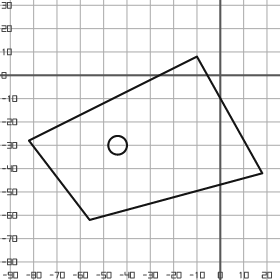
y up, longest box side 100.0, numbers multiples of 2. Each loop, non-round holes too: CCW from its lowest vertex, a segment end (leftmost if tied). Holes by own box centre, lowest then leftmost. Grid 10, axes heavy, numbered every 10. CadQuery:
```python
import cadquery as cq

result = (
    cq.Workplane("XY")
    .moveTo(-56.0, -62.0)
    .lineTo(18.0, -42.0)
    .lineTo(-10.0, 8.0)
    .lineTo(-82.0, -28.0)
    .close()
    .moveTo(-44.0, -30.0)
    .circle(4.0)
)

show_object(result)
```